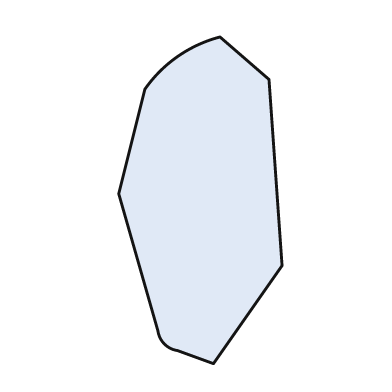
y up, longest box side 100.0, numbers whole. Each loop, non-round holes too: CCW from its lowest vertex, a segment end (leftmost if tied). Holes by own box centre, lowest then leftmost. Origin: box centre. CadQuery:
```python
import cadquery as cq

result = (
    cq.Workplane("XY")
    .moveTo(4.0, -50.0)
    .lineTo(25.0, -20.0)
    .lineTo(21.0, 37.0)
    .lineTo(6.0, 50.0)
    .threePointArc((-7.0, 44.0), (-17.0, 34.0))
    .lineTo(-25.0, 2.0)
    .lineTo(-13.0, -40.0)
    .threePointArc((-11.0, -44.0), (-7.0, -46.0))
    .close()
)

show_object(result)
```